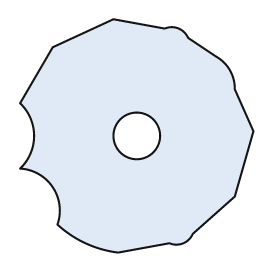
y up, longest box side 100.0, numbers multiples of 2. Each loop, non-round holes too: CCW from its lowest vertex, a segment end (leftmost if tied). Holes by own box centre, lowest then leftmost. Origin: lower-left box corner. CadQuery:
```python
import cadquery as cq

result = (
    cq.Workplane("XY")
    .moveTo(42.0, 0.0)
    .lineTo(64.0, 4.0)
    .threePointArc((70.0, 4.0), (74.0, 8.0))
    .lineTo(92.0, 24.0)
    .lineTo(100.0, 52.0)
    .lineTo(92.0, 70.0)
    .threePointArc((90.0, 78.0), (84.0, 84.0))
    .lineTo(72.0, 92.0)
    .threePointArc((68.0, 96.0), (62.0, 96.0))
    .lineTo(40.0, 100.0)
    .lineTo(14.0, 88.0)
    .lineTo(0.0, 64.0)
    .threePointArc((6.0, 50.0), (0.0, 36.0))
    .threePointArc((14.0, 28.0), (16.0, 12.0))
    .threePointArc((28.0, 4.0), (42.0, 0.0))
    .close()
    .moveTo(50.0, 50.0)
    .circle(10.0)
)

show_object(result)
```